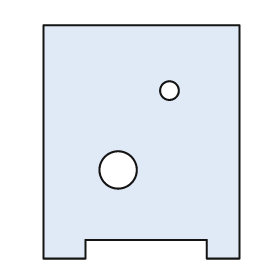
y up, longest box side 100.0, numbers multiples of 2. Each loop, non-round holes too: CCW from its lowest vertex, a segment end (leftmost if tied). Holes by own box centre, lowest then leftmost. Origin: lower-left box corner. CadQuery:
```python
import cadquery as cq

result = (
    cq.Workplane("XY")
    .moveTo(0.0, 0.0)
    .lineTo(18.0, 0.0)
    .lineTo(18.0, 8.0)
    .lineTo(70.0, 8.0)
    .lineTo(70.0, 0.0)
    .lineTo(84.0, 0.0)
    .lineTo(84.0, 100.0)
    .lineTo(0.0, 100.0)
    .close()
    .moveTo(32.0, 38.0)
    .circle(8.0)
    .moveTo(54.0, 72.0)
    .circle(4.0)
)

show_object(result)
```